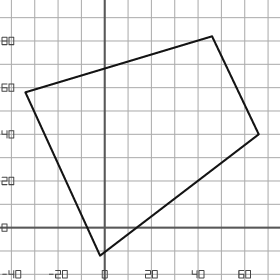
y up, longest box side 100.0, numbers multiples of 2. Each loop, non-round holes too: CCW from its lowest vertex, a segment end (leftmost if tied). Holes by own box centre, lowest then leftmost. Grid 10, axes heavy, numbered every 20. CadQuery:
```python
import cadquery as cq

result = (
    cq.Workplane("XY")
    .moveTo(-2.0, -12.0)
    .lineTo(66.0, 40.0)
    .lineTo(46.0, 82.0)
    .lineTo(-34.0, 58.0)
    .close()
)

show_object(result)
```